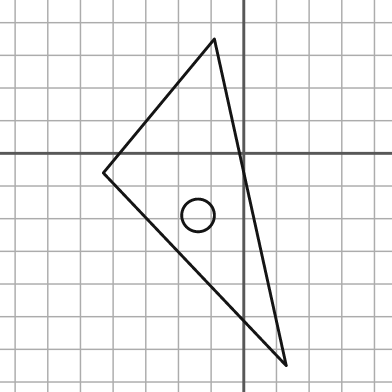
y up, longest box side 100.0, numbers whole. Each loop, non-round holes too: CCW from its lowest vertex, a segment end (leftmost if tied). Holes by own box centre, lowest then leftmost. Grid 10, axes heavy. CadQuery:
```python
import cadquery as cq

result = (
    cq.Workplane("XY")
    .moveTo(13.0, -65.0)
    .lineTo(-9.0, 35.0)
    .lineTo(-43.0, -6.0)
    .close()
    .moveTo(-14.0, -19.0)
    .circle(5.0)
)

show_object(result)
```